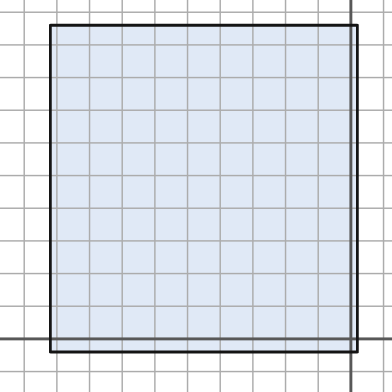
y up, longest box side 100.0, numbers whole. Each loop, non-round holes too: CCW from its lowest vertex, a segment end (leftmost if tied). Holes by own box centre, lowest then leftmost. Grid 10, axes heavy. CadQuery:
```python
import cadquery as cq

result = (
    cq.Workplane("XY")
    .moveTo(-92.0, -4.0)
    .lineTo(2.0, -4.0)
    .lineTo(2.0, 96.0)
    .lineTo(-92.0, 96.0)
    .close()
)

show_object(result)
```